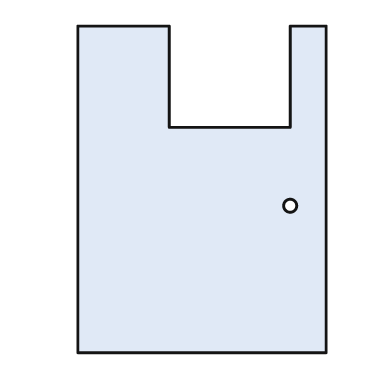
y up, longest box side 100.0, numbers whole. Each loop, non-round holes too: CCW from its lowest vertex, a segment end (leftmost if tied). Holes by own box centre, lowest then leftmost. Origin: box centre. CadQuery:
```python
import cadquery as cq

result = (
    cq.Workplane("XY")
    .moveTo(-38.0, -50.0)
    .lineTo(38.0, -50.0)
    .lineTo(38.0, 50.0)
    .lineTo(27.0, 50.0)
    .lineTo(27.0, 19.0)
    .lineTo(-10.0, 19.0)
    .lineTo(-10.0, 50.0)
    .lineTo(-38.0, 50.0)
    .close()
    .moveTo(27.0, -5.0)
    .circle(2.0)
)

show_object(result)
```